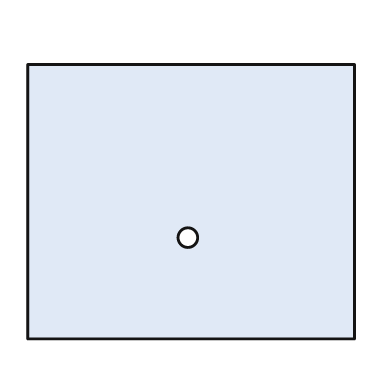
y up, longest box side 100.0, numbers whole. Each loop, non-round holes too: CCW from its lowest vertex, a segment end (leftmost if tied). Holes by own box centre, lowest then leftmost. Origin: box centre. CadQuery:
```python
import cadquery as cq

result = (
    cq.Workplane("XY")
    .moveTo(-50.0, -42.0)
    .lineTo(50.0, -42.0)
    .lineTo(50.0, 42.0)
    .lineTo(-50.0, 42.0)
    .close()
    .moveTo(-1.0, -11.0)
    .circle(3.0)
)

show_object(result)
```